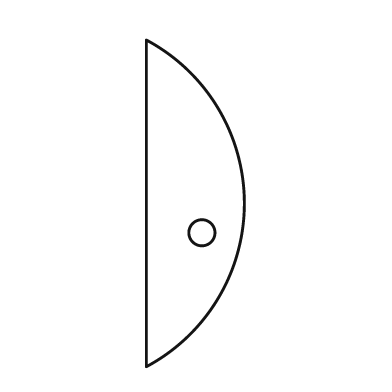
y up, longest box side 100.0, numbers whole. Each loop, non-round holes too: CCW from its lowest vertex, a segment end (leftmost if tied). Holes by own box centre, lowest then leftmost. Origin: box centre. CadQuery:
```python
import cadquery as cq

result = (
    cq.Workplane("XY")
    .moveTo(-15.0, -50.0)
    .threePointArc((15.0, 0.0), (-15.0, 50.0))
    .close()
    .moveTo(2.0, -9.0)
    .circle(4.0)
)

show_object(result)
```